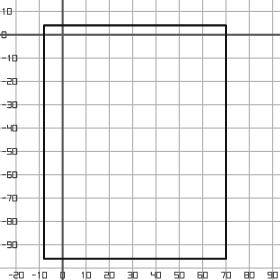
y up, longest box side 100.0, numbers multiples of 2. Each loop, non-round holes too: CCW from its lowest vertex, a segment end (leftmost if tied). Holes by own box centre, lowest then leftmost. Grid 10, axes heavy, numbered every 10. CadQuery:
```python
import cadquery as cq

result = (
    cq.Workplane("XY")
    .moveTo(-8.0, -96.0)
    .lineTo(70.0, -96.0)
    .lineTo(70.0, 4.0)
    .lineTo(-8.0, 4.0)
    .close()
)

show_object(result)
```